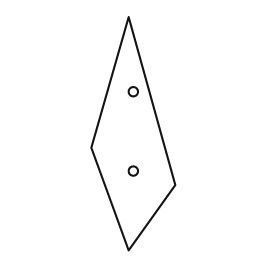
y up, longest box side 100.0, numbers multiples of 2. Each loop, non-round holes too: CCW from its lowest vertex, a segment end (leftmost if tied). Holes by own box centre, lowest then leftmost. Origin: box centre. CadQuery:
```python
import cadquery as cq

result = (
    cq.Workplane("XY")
    .moveTo(-2.0, -50.0)
    .lineTo(18.0, -22.0)
    .lineTo(-2.0, 50.0)
    .lineTo(-18.0, -6.0)
    .close()
    .moveTo(0.0, -16.0)
    .circle(2.0)
    .moveTo(0.0, 18.0)
    .circle(2.0)
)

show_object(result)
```